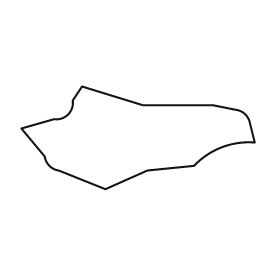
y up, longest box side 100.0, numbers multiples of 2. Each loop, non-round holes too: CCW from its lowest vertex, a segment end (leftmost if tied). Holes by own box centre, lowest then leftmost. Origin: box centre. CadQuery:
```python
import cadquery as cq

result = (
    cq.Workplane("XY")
    .moveTo(-14.0, -22.0)
    .lineTo(4.0, -14.0)
    .lineTo(24.0, -12.0)
    .threePointArc((36.0, -4.0), (50.0, -2.0))
    .lineTo(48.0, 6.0)
    .threePointArc((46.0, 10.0), (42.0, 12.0))
    .lineTo(32.0, 14.0)
    .lineTo(2.0, 14.0)
    .lineTo(-24.0, 22.0)
    .lineTo(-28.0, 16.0)
    .threePointArc((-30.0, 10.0), (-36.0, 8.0))
    .lineTo(-50.0, 4.0)
    .lineTo(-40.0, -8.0)
    .threePointArc((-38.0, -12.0), (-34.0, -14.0))
    .close()
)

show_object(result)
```